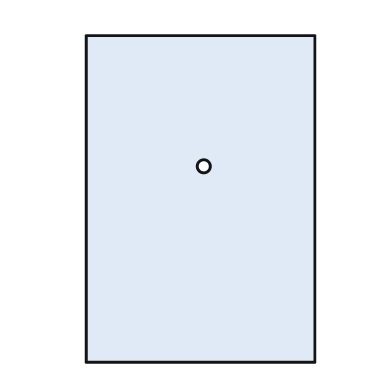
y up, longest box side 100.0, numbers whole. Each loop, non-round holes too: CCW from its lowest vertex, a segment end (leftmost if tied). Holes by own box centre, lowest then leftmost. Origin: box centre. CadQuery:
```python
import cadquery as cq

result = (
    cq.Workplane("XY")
    .moveTo(-35.0, -50.0)
    .lineTo(35.0, -50.0)
    .lineTo(35.0, 50.0)
    .lineTo(-35.0, 50.0)
    .close()
    .moveTo(1.0, 10.0)
    .circle(2.0)
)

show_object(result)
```